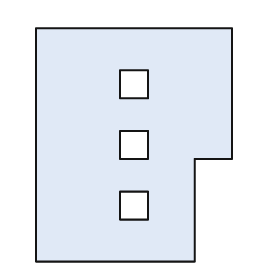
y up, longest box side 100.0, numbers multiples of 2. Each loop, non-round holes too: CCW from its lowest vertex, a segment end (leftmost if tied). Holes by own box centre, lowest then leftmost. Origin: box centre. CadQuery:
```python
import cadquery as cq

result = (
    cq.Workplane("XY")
    .moveTo(-42.0, -50.0)
    .lineTo(26.0, -50.0)
    .lineTo(26.0, -6.0)
    .lineTo(42.0, -6.0)
    .lineTo(42.0, 50.0)
    .lineTo(-42.0, 50.0)
    .close()
    .moveTo(-6.0, -32.0)
    .lineTo(6.0, -32.0)
    .lineTo(6.0, -20.0)
    .lineTo(-6.0, -20.0)
    .close()
    .moveTo(-6.0, -6.0)
    .lineTo(6.0, -6.0)
    .lineTo(6.0, 6.0)
    .lineTo(-6.0, 6.0)
    .close()
    .moveTo(-6.0, 20.0)
    .lineTo(6.0, 20.0)
    .lineTo(6.0, 32.0)
    .lineTo(-6.0, 32.0)
    .close()
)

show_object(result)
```